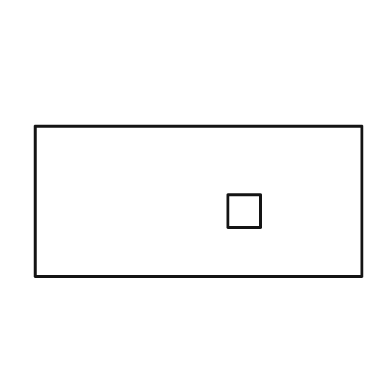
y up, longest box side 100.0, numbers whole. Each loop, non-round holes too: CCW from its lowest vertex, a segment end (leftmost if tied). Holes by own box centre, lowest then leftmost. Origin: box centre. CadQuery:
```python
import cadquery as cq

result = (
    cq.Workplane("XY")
    .moveTo(-50.0, -23.0)
    .lineTo(50.0, -23.0)
    .lineTo(50.0, 23.0)
    .lineTo(-50.0, 23.0)
    .close()
    .moveTo(9.0, -8.0)
    .lineTo(19.0, -8.0)
    .lineTo(19.0, 2.0)
    .lineTo(9.0, 2.0)
    .close()
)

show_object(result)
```